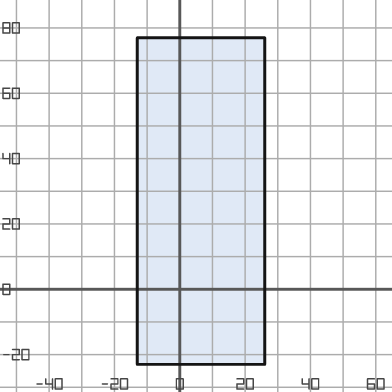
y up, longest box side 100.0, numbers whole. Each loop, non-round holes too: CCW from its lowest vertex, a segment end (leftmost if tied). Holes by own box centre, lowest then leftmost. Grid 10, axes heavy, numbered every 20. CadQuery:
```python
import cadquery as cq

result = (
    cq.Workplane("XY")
    .moveTo(-13.0, -23.0)
    .lineTo(26.0, -23.0)
    .lineTo(26.0, 77.0)
    .lineTo(-13.0, 77.0)
    .close()
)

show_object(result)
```